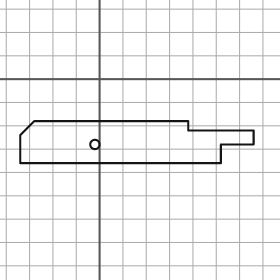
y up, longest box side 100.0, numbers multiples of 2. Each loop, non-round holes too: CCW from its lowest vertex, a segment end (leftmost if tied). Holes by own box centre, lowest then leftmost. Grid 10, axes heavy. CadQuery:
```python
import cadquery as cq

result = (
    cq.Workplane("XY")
    .moveTo(-34.0, -36.0)
    .lineTo(52.0, -36.0)
    .lineTo(52.0, -28.0)
    .lineTo(66.0, -28.0)
    .lineTo(66.0, -22.0)
    .lineTo(38.0, -22.0)
    .lineTo(38.0, -18.0)
    .lineTo(-28.0, -18.0)
    .lineTo(-34.0, -24.0)
    .close()
    .moveTo(-2.0, -28.0)
    .circle(2.0)
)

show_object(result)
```